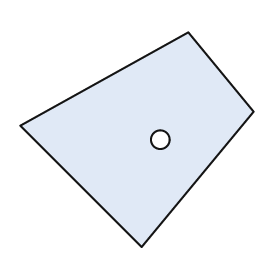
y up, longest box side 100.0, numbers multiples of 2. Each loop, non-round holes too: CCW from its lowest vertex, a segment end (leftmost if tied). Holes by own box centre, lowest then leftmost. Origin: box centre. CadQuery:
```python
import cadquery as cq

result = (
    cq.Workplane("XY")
    .moveTo(2.0, -46.0)
    .lineTo(50.0, 12.0)
    .lineTo(22.0, 46.0)
    .lineTo(-50.0, 6.0)
    .close()
    .moveTo(10.0, 0.0)
    .circle(4.0)
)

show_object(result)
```